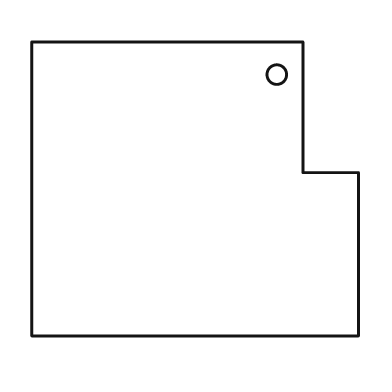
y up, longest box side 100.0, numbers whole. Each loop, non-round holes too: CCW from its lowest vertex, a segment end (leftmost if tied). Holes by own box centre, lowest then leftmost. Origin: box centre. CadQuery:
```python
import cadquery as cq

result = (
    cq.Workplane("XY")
    .moveTo(-50.0, -45.0)
    .lineTo(50.0, -45.0)
    .lineTo(50.0, 5.0)
    .lineTo(33.0, 5.0)
    .lineTo(33.0, 45.0)
    .lineTo(-50.0, 45.0)
    .close()
    .moveTo(25.0, 35.0)
    .circle(3.0)
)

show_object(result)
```